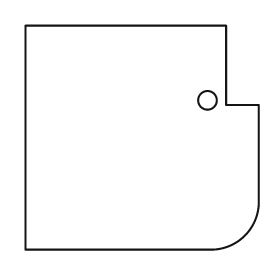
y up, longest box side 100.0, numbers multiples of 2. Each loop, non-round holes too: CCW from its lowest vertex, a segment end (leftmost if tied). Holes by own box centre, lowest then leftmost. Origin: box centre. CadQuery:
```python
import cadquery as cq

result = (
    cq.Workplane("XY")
    .moveTo(-50.0, -48.0)
    .lineTo(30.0, -48.0)
    .threePointArc((44.0, -42.0), (50.0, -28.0))
    .lineTo(50.0, 14.0)
    .lineTo(36.0, 14.0)
    .lineTo(36.0, 48.0)
    .lineTo(-50.0, 48.0)
    .close()
    .moveTo(28.0, 16.0)
    .circle(4.0)
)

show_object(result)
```